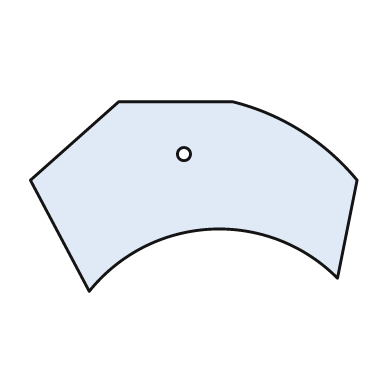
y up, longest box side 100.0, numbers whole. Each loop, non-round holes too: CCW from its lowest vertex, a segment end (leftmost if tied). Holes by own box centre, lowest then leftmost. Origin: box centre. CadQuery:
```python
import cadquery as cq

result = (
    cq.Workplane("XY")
    .moveTo(-32.0, -29.0)
    .threePointArc((5.0, -10.0), (44.0, -25.0))
    .lineTo(50.0, 5.0)
    .threePointArc((33.0, 20.0), (12.0, 29.0))
    .lineTo(-23.0, 29.0)
    .lineTo(-50.0, 5.0)
    .close()
    .moveTo(-3.0, 13.0)
    .circle(2.0)
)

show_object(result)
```